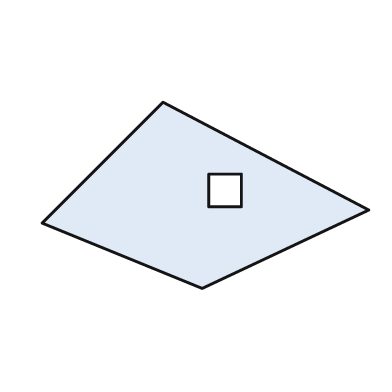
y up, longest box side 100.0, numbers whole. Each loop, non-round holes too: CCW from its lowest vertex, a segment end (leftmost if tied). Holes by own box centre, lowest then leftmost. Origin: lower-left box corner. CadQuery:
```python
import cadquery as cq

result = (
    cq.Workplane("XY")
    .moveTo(49.0, 0.0)
    .lineTo(100.0, 24.0)
    .lineTo(37.0, 57.0)
    .lineTo(0.0, 20.0)
    .close()
    .moveTo(51.0, 25.0)
    .lineTo(61.0, 25.0)
    .lineTo(61.0, 35.0)
    .lineTo(51.0, 35.0)
    .close()
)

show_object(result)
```